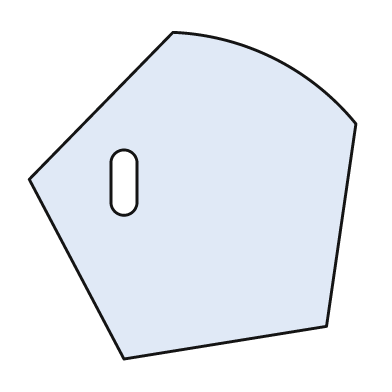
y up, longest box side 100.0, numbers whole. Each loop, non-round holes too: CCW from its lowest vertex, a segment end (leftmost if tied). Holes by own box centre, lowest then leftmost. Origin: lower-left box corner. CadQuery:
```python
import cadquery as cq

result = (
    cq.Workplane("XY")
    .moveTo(29.0, 0.0)
    .lineTo(91.0, 10.0)
    .lineTo(100.0, 72.0)
    .threePointArc((75.0, 92.0), (44.0, 100.0))
    .lineTo(0.0, 55.0)
    .close()
    .moveTo(25.0, 48.0)
    .threePointArc((29.0, 44.0), (33.0, 48.0))
    .lineTo(33.0, 60.0)
    .threePointArc((29.0, 64.0), (25.0, 60.0))
    .close()
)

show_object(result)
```